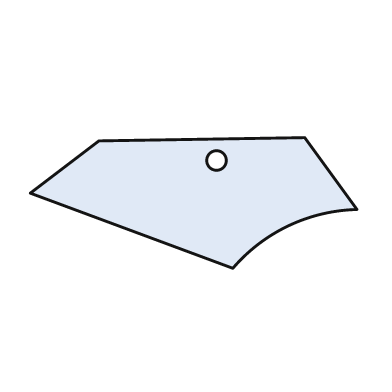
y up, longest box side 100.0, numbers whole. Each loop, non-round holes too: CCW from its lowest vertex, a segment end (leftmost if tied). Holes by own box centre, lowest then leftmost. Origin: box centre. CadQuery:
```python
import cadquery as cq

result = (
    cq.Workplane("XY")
    .moveTo(12.0, -20.0)
    .threePointArc((29.0, -7.0), (50.0, -2.0))
    .lineTo(34.0, 20.0)
    .lineTo(-29.0, 19.0)
    .lineTo(-50.0, 3.0)
    .close()
    .moveTo(7.0, 13.0)
    .circle(3.0)
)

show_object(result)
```